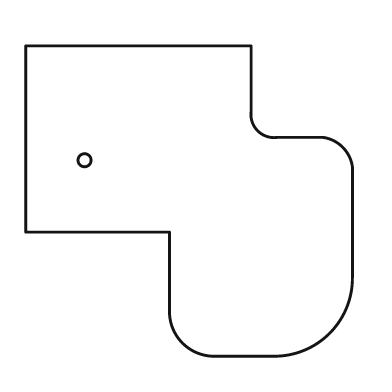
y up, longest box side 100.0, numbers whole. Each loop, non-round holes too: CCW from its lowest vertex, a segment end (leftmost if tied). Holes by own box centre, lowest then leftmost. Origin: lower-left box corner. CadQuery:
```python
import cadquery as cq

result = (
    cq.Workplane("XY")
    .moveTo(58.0, 0.0)
    .lineTo(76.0, 0.0)
    .threePointArc((93.0, 7.0), (100.0, 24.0))
    .lineTo(100.0, 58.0)
    .threePointArc((97.0, 64.0), (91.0, 67.0))
    .lineTo(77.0, 67.0)
    .threePointArc((71.0, 69.0), (69.0, 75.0))
    .lineTo(69.0, 95.0)
    .lineTo(0.0, 95.0)
    .lineTo(0.0, 38.0)
    .lineTo(44.0, 38.0)
    .lineTo(44.0, 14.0)
    .threePointArc((48.0, 4.0), (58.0, 0.0))
    .close()
    .moveTo(18.0, 60.0)
    .circle(2.0)
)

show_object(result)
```